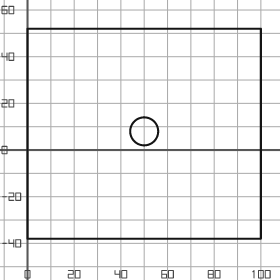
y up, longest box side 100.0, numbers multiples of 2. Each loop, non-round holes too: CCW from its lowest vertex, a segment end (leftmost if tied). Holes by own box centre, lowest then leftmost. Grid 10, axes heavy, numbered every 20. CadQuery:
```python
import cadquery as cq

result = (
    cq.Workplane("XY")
    .moveTo(0.0, -38.0)
    .lineTo(100.0, -38.0)
    .lineTo(100.0, 52.0)
    .lineTo(0.0, 52.0)
    .close()
    .moveTo(50.0, 8.0)
    .circle(6.0)
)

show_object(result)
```